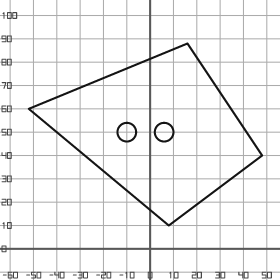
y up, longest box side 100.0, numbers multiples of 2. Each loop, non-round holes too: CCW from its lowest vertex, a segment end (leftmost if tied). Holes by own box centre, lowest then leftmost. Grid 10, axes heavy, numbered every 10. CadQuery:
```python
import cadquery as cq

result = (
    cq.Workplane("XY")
    .moveTo(8.0, 10.0)
    .lineTo(48.0, 40.0)
    .lineTo(16.0, 88.0)
    .lineTo(-52.0, 60.0)
    .close()
    .moveTo(-10.0, 50.0)
    .circle(4.0)
    .moveTo(6.0, 50.0)
    .circle(4.0)
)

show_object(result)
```